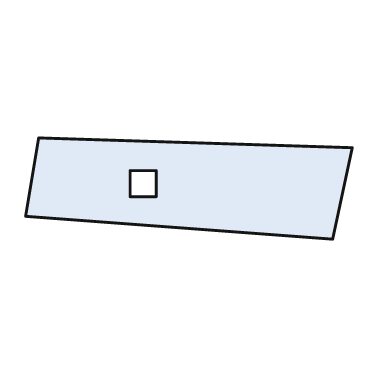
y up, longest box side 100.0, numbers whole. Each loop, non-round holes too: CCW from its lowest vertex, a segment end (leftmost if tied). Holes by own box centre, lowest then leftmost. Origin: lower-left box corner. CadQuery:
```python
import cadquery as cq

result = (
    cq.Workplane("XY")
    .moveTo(94.0, 0.0)
    .lineTo(100.0, 28.0)
    .lineTo(4.0, 31.0)
    .lineTo(0.0, 7.0)
    .close()
    .moveTo(32.0, 13.0)
    .lineTo(40.0, 13.0)
    .lineTo(40.0, 21.0)
    .lineTo(32.0, 21.0)
    .close()
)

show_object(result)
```